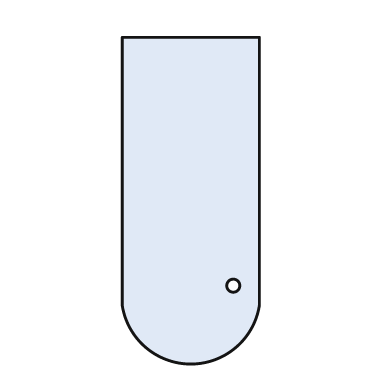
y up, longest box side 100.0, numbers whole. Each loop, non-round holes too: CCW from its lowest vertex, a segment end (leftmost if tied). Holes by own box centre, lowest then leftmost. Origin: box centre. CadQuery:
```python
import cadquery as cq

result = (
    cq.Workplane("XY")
    .moveTo(-21.0, -32.0)
    .threePointArc((0.0, -50.0), (21.0, -32.0))
    .lineTo(21.0, 50.0)
    .lineTo(-21.0, 50.0)
    .close()
    .moveTo(13.0, -26.0)
    .circle(2.0)
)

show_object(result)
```